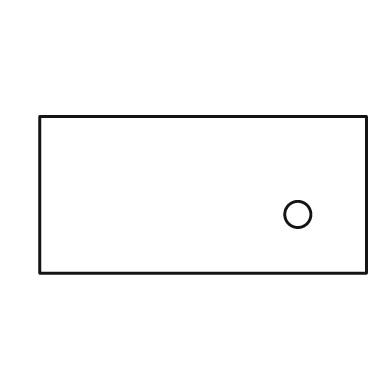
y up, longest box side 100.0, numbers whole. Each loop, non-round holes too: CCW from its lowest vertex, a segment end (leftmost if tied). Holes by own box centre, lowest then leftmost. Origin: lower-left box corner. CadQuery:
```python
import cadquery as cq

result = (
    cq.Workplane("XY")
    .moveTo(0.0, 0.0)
    .lineTo(100.0, 0.0)
    .lineTo(100.0, 48.0)
    .lineTo(0.0, 48.0)
    .close()
    .moveTo(79.0, 18.0)
    .circle(4.0)
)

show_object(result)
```